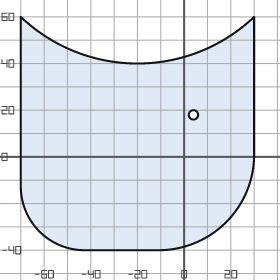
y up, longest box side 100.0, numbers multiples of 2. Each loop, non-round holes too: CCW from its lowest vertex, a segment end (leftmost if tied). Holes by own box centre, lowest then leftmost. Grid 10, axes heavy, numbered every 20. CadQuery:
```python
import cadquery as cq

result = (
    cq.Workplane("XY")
    .moveTo(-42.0, -40.0)
    .lineTo(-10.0, -40.0)
    .threePointArc((18.0, -28.0), (30.0, 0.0))
    .lineTo(30.0, 60.0)
    .threePointArc((-20.0, 40.0), (-70.0, 60.0))
    .lineTo(-70.0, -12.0)
    .threePointArc((-62.0, -32.0), (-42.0, -40.0))
    .close()
    .moveTo(4.0, 18.0)
    .circle(2.0)
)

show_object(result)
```